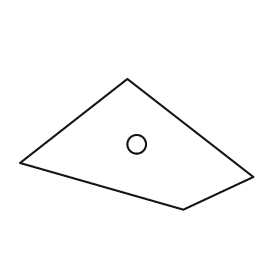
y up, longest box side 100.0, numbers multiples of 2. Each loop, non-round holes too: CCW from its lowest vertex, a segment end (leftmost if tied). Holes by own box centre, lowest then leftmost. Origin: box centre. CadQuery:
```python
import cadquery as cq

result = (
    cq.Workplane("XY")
    .moveTo(20.0, -28.0)
    .lineTo(50.0, -14.0)
    .lineTo(-4.0, 28.0)
    .lineTo(-50.0, -8.0)
    .close()
    .moveTo(0.0, 0.0)
    .circle(4.0)
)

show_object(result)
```